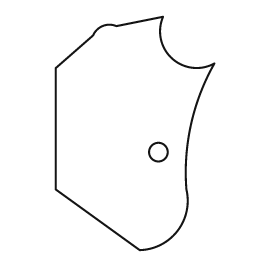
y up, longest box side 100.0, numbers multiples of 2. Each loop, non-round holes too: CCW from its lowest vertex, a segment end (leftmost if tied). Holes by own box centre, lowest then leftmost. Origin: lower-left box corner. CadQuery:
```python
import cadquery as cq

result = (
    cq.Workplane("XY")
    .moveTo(36.0, 0.0)
    .threePointArc((52.0, 8.0), (56.0, 26.0))
    .threePointArc((58.0, 54.0), (68.0, 80.0))
    .threePointArc((50.0, 82.0), (46.0, 100.0))
    .lineTo(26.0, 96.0)
    .threePointArc((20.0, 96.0), (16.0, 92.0))
    .lineTo(0.0, 78.0)
    .lineTo(0.0, 26.0)
    .close()
    .moveTo(44.0, 42.0)
    .circle(4.0)
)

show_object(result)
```